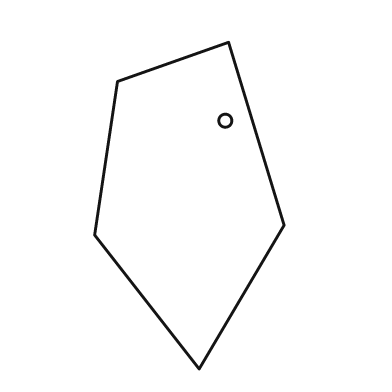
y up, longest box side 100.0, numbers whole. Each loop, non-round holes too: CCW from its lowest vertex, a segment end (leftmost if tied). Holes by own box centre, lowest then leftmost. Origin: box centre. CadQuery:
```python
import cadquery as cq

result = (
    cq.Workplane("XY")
    .moveTo(3.0, -50.0)
    .lineTo(29.0, -6.0)
    .lineTo(12.0, 50.0)
    .lineTo(-22.0, 38.0)
    .lineTo(-29.0, -9.0)
    .close()
    .moveTo(11.0, 26.0)
    .circle(2.0)
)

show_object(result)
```